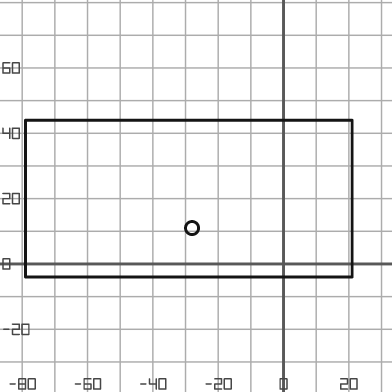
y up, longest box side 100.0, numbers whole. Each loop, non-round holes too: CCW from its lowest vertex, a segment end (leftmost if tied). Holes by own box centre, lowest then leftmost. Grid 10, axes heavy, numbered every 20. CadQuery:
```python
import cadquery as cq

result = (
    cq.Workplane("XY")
    .moveTo(-79.0, -4.0)
    .lineTo(21.0, -4.0)
    .lineTo(21.0, 44.0)
    .lineTo(-79.0, 44.0)
    .close()
    .moveTo(-28.0, 11.0)
    .circle(2.0)
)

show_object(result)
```